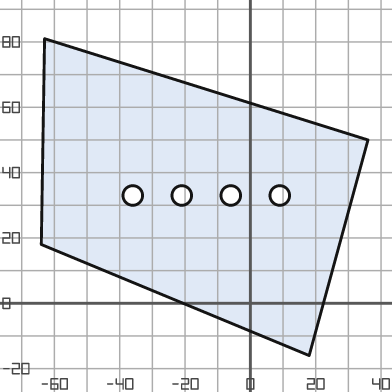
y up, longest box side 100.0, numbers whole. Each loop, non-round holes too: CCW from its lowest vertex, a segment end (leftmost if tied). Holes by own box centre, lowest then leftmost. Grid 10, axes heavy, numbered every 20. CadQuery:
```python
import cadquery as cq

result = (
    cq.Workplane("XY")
    .moveTo(18.0, -16.0)
    .lineTo(36.0, 50.0)
    .lineTo(-63.0, 81.0)
    .lineTo(-64.0, 18.0)
    .close()
    .moveTo(-36.0, 33.0)
    .circle(3.0)
    .moveTo(-21.0, 33.0)
    .circle(3.0)
    .moveTo(-6.0, 33.0)
    .circle(3.0)
    .moveTo(9.0, 33.0)
    .circle(3.0)
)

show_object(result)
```